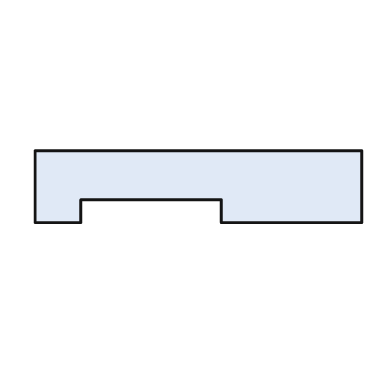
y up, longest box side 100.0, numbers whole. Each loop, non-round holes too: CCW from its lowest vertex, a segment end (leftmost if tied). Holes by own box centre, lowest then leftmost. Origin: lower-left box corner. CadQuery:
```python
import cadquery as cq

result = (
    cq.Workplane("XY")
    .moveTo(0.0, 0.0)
    .lineTo(14.0, 0.0)
    .lineTo(14.0, 7.0)
    .lineTo(57.0, 7.0)
    .lineTo(57.0, 0.0)
    .lineTo(100.0, 0.0)
    .lineTo(100.0, 22.0)
    .lineTo(0.0, 22.0)
    .close()
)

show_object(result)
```